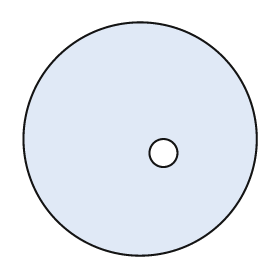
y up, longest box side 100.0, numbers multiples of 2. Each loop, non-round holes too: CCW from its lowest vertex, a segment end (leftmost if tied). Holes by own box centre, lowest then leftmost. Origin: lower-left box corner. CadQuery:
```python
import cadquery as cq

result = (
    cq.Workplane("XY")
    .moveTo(50.0, 50.0)
    .circle(50.0)
    .moveTo(60.0, 44.0)
    .circle(6.0)
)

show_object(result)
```